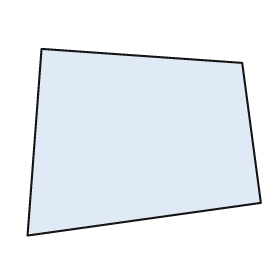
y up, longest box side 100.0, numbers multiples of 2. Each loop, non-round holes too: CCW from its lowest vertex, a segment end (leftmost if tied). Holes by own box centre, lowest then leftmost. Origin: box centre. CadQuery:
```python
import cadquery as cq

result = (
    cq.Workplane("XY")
    .moveTo(-50.0, -40.0)
    .lineTo(50.0, -26.0)
    .lineTo(42.0, 34.0)
    .lineTo(-44.0, 40.0)
    .close()
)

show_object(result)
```